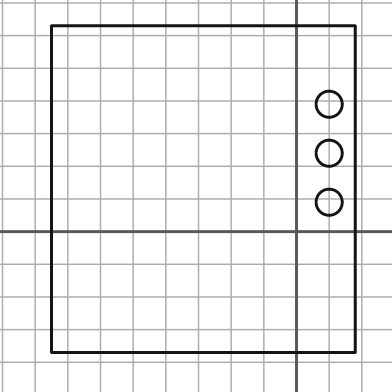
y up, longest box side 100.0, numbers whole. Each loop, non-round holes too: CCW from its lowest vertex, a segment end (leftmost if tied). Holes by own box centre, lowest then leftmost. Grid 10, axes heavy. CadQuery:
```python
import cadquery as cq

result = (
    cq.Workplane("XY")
    .moveTo(-75.0, -37.0)
    .lineTo(18.0, -37.0)
    .lineTo(18.0, 63.0)
    .lineTo(-75.0, 63.0)
    .close()
    .moveTo(10.0, 9.0)
    .circle(4.0)
    .moveTo(10.0, 24.0)
    .circle(4.0)
    .moveTo(10.0, 39.0)
    .circle(4.0)
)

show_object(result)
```